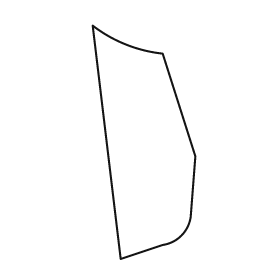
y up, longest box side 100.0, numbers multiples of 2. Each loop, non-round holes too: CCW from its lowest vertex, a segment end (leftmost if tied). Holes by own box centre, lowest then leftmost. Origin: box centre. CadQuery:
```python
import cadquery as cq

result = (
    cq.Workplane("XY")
    .moveTo(-10.0, -50.0)
    .lineTo(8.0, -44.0)
    .threePointArc((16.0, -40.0), (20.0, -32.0))
    .lineTo(22.0, -6.0)
    .lineTo(8.0, 38.0)
    .threePointArc((-8.0, 42.0), (-22.0, 50.0))
    .close()
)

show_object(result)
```